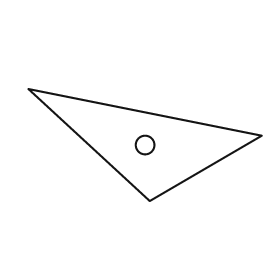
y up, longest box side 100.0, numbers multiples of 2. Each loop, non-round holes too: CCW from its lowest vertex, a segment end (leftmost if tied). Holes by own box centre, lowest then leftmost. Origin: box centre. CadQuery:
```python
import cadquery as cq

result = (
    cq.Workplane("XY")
    .moveTo(2.0, -24.0)
    .lineTo(50.0, 4.0)
    .lineTo(-50.0, 24.0)
    .close()
    .moveTo(0.0, 0.0)
    .circle(4.0)
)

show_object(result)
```